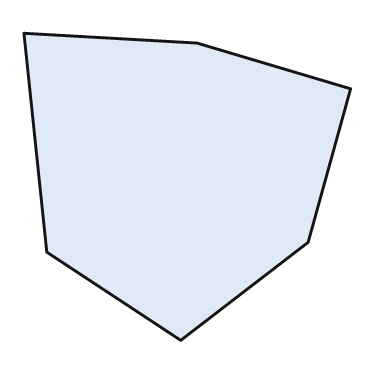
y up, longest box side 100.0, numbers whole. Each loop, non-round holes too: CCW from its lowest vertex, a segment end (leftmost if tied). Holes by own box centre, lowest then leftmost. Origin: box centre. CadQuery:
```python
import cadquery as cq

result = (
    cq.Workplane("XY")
    .moveTo(-2.0, -47.0)
    .lineTo(37.0, -17.0)
    .lineTo(50.0, 30.0)
    .lineTo(3.0, 44.0)
    .lineTo(-50.0, 47.0)
    .lineTo(-43.0, -20.0)
    .close()
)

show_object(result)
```